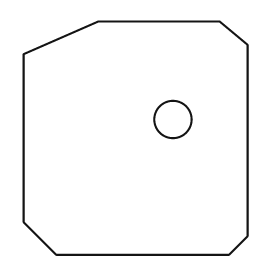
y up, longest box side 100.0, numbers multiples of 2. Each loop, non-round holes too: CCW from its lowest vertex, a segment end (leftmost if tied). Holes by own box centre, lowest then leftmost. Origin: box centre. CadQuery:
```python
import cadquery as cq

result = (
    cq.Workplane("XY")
    .moveTo(-34.0, -50.0)
    .lineTo(40.0, -50.0)
    .lineTo(48.0, -42.0)
    .lineTo(48.0, 40.0)
    .lineTo(36.0, 50.0)
    .lineTo(-16.0, 50.0)
    .lineTo(-48.0, 36.0)
    .lineTo(-48.0, -36.0)
    .close()
    .moveTo(16.0, 8.0)
    .circle(8.0)
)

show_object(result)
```